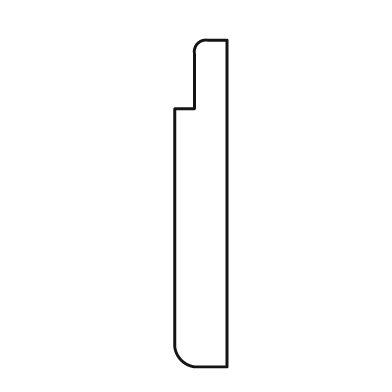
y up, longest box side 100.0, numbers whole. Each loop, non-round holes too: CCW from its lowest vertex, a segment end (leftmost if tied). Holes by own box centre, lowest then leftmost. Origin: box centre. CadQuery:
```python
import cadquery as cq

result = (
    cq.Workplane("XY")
    .moveTo(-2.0, -50.0)
    .lineTo(8.0, -50.0)
    .lineTo(8.0, 50.0)
    .lineTo(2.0, 50.0)
    .threePointArc((-1.0, 49.0), (-2.0, 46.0))
    .lineTo(-2.0, 29.0)
    .lineTo(-8.0, 29.0)
    .lineTo(-8.0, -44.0)
    .threePointArc((-6.0, -48.0), (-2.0, -50.0))
    .close()
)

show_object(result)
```